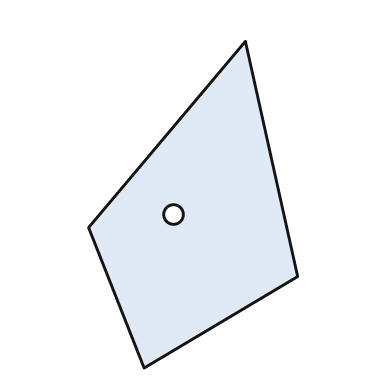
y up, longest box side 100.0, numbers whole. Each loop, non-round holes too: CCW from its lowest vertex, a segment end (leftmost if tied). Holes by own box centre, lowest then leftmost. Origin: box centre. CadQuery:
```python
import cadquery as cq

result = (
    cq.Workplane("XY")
    .moveTo(-15.0, -50.0)
    .lineTo(32.0, -22.0)
    .lineTo(16.0, 50.0)
    .lineTo(-32.0, -7.0)
    .close()
    .moveTo(-6.0, -3.0)
    .circle(3.0)
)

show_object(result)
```